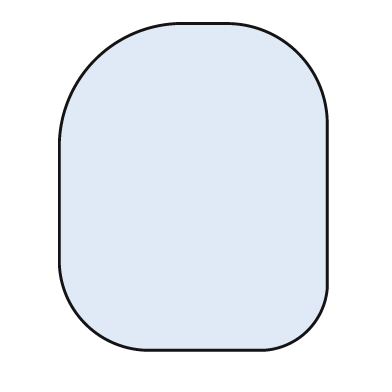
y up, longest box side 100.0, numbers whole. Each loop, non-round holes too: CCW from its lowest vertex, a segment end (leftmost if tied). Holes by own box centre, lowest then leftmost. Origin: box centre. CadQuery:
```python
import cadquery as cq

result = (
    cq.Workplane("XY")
    .moveTo(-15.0, -50.0)
    .lineTo(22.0, -50.0)
    .threePointArc((35.0, -44.0), (41.0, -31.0))
    .lineTo(41.0, 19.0)
    .threePointArc((32.0, 41.0), (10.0, 50.0))
    .lineTo(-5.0, 50.0)
    .threePointArc((-30.0, 39.0), (-41.0, 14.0))
    .lineTo(-41.0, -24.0)
    .threePointArc((-33.0, -42.0), (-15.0, -50.0))
    .close()
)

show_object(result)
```